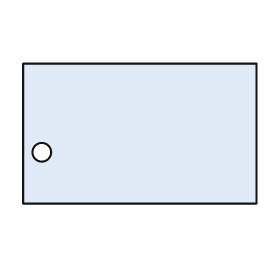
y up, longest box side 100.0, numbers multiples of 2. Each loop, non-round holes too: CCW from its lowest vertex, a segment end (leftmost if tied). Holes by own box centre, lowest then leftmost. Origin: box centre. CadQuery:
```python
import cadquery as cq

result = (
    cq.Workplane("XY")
    .moveTo(-50.0, -30.0)
    .lineTo(50.0, -30.0)
    .lineTo(50.0, 30.0)
    .lineTo(-50.0, 30.0)
    .close()
    .moveTo(-42.0, -8.0)
    .circle(4.0)
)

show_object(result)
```